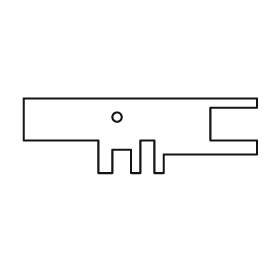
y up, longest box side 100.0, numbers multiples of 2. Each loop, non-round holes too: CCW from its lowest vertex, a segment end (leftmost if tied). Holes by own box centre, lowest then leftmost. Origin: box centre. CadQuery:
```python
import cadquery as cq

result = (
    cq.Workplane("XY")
    .moveTo(-18.0, -16.0)
    .lineTo(-12.0, -16.0)
    .lineTo(-12.0, -6.0)
    .lineTo(-4.0, -6.0)
    .lineTo(-4.0, -16.0)
    .lineTo(0.0, -16.0)
    .lineTo(0.0, -2.0)
    .lineTo(6.0, -2.0)
    .lineTo(6.0, -16.0)
    .lineTo(10.0, -16.0)
    .lineTo(10.0, -8.0)
    .lineTo(50.0, -8.0)
    .lineTo(50.0, -2.0)
    .lineTo(30.0, -2.0)
    .lineTo(30.0, 12.0)
    .lineTo(50.0, 12.0)
    .lineTo(50.0, 16.0)
    .lineTo(-50.0, 16.0)
    .lineTo(-50.0, -2.0)
    .lineTo(-18.0, -2.0)
    .close()
    .moveTo(-10.0, 8.0)
    .circle(2.0)
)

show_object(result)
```